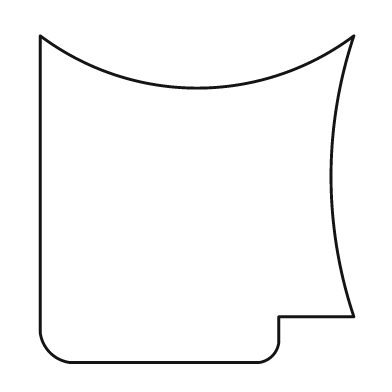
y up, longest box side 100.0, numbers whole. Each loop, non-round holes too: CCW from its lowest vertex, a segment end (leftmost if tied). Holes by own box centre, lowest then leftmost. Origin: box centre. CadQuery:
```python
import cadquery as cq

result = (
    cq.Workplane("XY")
    .moveTo(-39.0, -50.0)
    .lineTo(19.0, -50.0)
    .threePointArc((23.0, -48.0), (25.0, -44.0))
    .lineTo(25.0, -36.0)
    .lineTo(48.0, -36.0)
    .threePointArc((41.0, 7.0), (48.0, 50.0))
    .threePointArc((0.0, 34.0), (-48.0, 50.0))
    .lineTo(-48.0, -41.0)
    .threePointArc((-45.0, -47.0), (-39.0, -50.0))
    .close()
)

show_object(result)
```